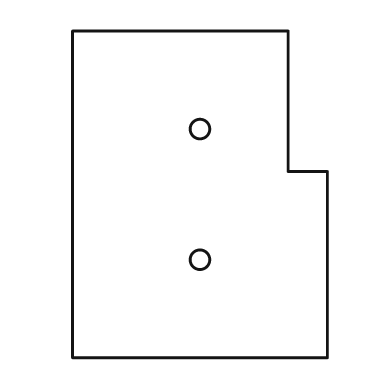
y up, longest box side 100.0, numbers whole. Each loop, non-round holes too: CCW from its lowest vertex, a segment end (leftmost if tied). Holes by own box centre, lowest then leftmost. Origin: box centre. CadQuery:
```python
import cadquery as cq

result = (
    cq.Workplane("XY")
    .moveTo(-39.0, -50.0)
    .lineTo(39.0, -50.0)
    .lineTo(39.0, 7.0)
    .lineTo(27.0, 7.0)
    .lineTo(27.0, 50.0)
    .lineTo(-39.0, 50.0)
    .close()
    .moveTo(0.0, -20.0)
    .circle(3.0)
    .moveTo(0.0, 20.0)
    .circle(3.0)
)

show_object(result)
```